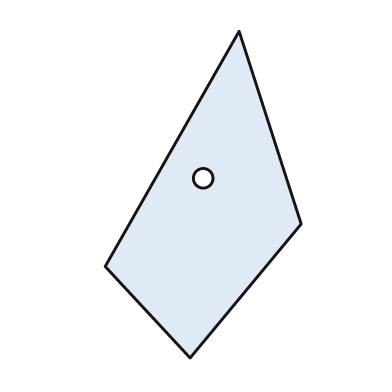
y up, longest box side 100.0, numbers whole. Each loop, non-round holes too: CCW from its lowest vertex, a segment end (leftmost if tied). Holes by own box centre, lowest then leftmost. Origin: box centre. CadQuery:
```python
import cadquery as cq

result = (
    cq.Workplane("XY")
    .moveTo(-4.0, -50.0)
    .lineTo(30.0, -9.0)
    .lineTo(11.0, 50.0)
    .lineTo(-30.0, -22.0)
    .close()
    .moveTo(0.0, 5.0)
    .circle(3.0)
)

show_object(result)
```